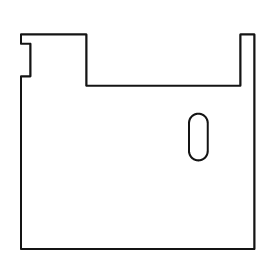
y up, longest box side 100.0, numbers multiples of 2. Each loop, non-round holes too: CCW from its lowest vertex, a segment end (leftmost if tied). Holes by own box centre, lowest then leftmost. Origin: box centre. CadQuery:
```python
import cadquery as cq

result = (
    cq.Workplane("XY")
    .moveTo(-50.0, -46.0)
    .lineTo(50.0, -46.0)
    .lineTo(50.0, 46.0)
    .lineTo(44.0, 46.0)
    .lineTo(44.0, 24.0)
    .lineTo(-22.0, 24.0)
    .lineTo(-22.0, 46.0)
    .lineTo(-50.0, 46.0)
    .lineTo(-50.0, 42.0)
    .lineTo(-46.0, 42.0)
    .lineTo(-46.0, 28.0)
    .lineTo(-50.0, 28.0)
    .close()
    .moveTo(22.0, -4.0)
    .threePointArc((26.0, -8.0), (30.0, -4.0))
    .lineTo(30.0, 8.0)
    .threePointArc((26.0, 12.0), (22.0, 8.0))
    .close()
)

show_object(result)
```